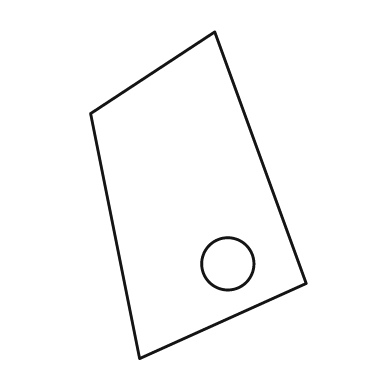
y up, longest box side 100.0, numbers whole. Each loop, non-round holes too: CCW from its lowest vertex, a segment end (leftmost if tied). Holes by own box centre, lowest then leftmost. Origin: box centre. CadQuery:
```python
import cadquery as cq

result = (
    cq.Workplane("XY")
    .moveTo(-18.0, -50.0)
    .lineTo(33.0, -27.0)
    .lineTo(5.0, 50.0)
    .lineTo(-33.0, 25.0)
    .close()
    .moveTo(9.0, -21.0)
    .circle(8.0)
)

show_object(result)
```